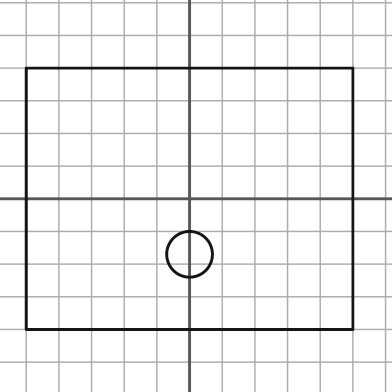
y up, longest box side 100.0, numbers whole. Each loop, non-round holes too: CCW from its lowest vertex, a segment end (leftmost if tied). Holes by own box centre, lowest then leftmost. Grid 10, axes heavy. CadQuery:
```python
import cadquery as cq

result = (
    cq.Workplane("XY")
    .moveTo(-50.0, -40.0)
    .lineTo(50.0, -40.0)
    .lineTo(50.0, 40.0)
    .lineTo(-50.0, 40.0)
    .close()
    .moveTo(0.0, -17.0)
    .circle(7.0)
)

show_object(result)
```